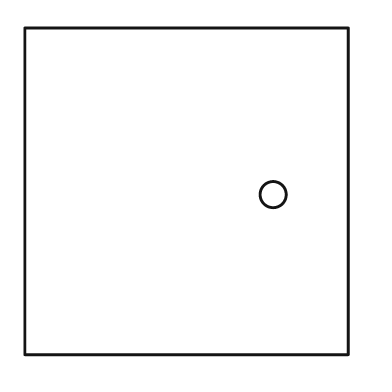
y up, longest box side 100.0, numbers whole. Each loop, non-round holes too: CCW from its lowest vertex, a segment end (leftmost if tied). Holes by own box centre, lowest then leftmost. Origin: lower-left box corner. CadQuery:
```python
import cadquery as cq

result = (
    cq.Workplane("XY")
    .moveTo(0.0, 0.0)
    .lineTo(99.0, 0.0)
    .lineTo(99.0, 100.0)
    .lineTo(0.0, 100.0)
    .close()
    .moveTo(76.0, 49.0)
    .circle(4.0)
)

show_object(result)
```